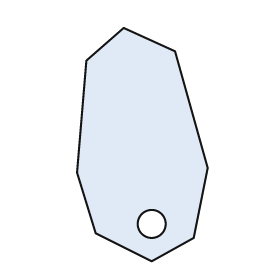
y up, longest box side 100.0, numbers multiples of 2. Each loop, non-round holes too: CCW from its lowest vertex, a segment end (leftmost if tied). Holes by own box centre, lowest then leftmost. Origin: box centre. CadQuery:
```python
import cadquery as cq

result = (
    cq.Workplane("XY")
    .moveTo(4.0, -50.0)
    .lineTo(22.0, -40.0)
    .lineTo(28.0, -10.0)
    .lineTo(14.0, 40.0)
    .lineTo(-8.0, 50.0)
    .lineTo(-24.0, 36.0)
    .lineTo(-28.0, -12.0)
    .lineTo(-20.0, -38.0)
    .close()
    .moveTo(4.0, -34.0)
    .circle(6.0)
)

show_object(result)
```